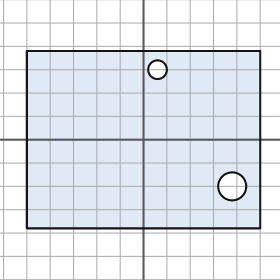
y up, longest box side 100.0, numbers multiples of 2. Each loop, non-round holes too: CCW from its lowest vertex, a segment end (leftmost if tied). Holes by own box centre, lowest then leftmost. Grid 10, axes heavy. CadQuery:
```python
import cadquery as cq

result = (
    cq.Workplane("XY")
    .moveTo(-50.0, -38.0)
    .lineTo(50.0, -38.0)
    .lineTo(50.0, 38.0)
    .lineTo(-50.0, 38.0)
    .close()
    .moveTo(38.0, -20.0)
    .circle(6.0)
    .moveTo(6.0, 30.0)
    .circle(4.0)
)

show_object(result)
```